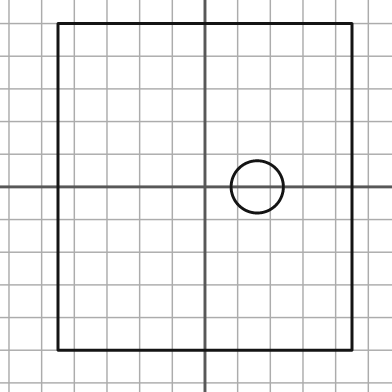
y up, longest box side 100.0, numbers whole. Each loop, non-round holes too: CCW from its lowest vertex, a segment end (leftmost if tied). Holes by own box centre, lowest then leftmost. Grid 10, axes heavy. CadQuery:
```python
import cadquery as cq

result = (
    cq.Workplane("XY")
    .moveTo(-45.0, -50.0)
    .lineTo(45.0, -50.0)
    .lineTo(45.0, 50.0)
    .lineTo(-45.0, 50.0)
    .close()
    .moveTo(16.0, 0.0)
    .circle(8.0)
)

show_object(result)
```